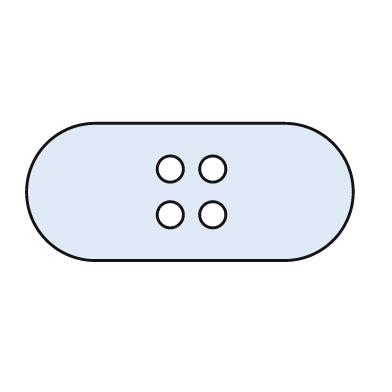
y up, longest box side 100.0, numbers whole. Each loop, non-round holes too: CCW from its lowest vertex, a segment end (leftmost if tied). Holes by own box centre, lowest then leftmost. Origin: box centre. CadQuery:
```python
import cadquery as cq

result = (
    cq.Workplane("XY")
    .moveTo(-29.0, -21.0)
    .lineTo(29.0, -21.0)
    .threePointArc((50.0, 0.0), (29.0, 21.0))
    .lineTo(-29.0, 21.0)
    .threePointArc((-50.0, 0.0), (-29.0, -21.0))
    .close()
    .moveTo(-6.0, -7.0)
    .circle(4.0)
    .moveTo(7.0, -7.0)
    .circle(4.0)
    .moveTo(-6.0, 7.0)
    .circle(4.0)
    .moveTo(7.0, 7.0)
    .circle(4.0)
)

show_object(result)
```